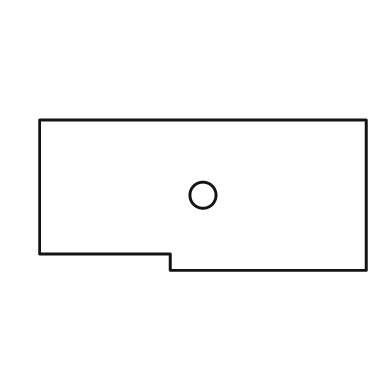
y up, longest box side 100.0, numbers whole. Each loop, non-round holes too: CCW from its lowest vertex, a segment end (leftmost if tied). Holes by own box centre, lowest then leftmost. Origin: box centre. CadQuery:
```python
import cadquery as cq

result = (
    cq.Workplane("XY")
    .moveTo(-10.0, -23.0)
    .lineTo(50.0, -23.0)
    .lineTo(50.0, 23.0)
    .lineTo(-50.0, 23.0)
    .lineTo(-50.0, -18.0)
    .lineTo(-10.0, -18.0)
    .close()
    .moveTo(0.0, 0.0)
    .circle(4.0)
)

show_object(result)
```